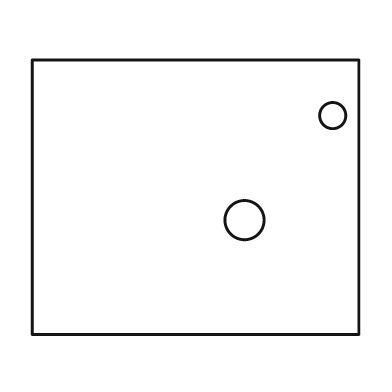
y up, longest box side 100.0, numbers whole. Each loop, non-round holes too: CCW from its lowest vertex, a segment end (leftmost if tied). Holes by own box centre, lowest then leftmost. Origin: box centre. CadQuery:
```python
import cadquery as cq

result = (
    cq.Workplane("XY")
    .moveTo(-50.0, -42.0)
    .lineTo(50.0, -42.0)
    .lineTo(50.0, 42.0)
    .lineTo(-50.0, 42.0)
    .close()
    .moveTo(15.0, -7.0)
    .circle(6.0)
    .moveTo(42.0, 25.0)
    .circle(4.0)
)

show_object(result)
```